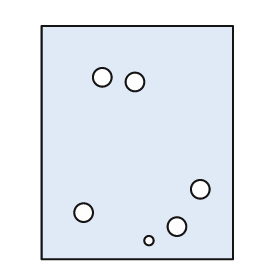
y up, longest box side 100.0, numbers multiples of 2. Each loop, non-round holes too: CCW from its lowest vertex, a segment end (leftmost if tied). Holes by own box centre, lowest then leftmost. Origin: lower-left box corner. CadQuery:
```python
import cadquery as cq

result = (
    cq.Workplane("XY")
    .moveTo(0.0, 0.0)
    .lineTo(82.0, 0.0)
    .lineTo(82.0, 100.0)
    .lineTo(0.0, 100.0)
    .close()
    .moveTo(46.0, 8.0)
    .circle(2.0)
    .moveTo(58.0, 14.0)
    .circle(4.0)
    .moveTo(18.0, 20.0)
    .circle(4.0)
    .moveTo(68.0, 30.0)
    .circle(4.0)
    .moveTo(40.0, 76.0)
    .circle(4.0)
    .moveTo(26.0, 78.0)
    .circle(4.0)
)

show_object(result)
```